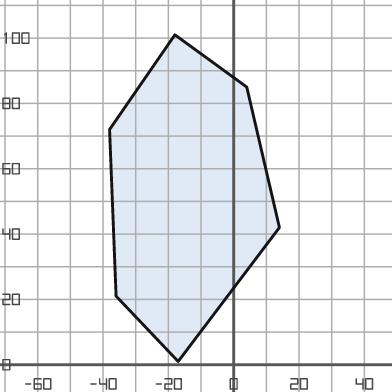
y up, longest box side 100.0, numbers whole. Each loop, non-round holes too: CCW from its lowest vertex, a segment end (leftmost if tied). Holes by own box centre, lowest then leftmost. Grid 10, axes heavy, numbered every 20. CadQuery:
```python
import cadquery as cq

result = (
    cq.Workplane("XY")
    .moveTo(-17.0, 1.0)
    .lineTo(14.0, 42.0)
    .lineTo(4.0, 85.0)
    .lineTo(-18.0, 101.0)
    .lineTo(-38.0, 72.0)
    .lineTo(-36.0, 21.0)
    .close()
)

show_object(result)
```